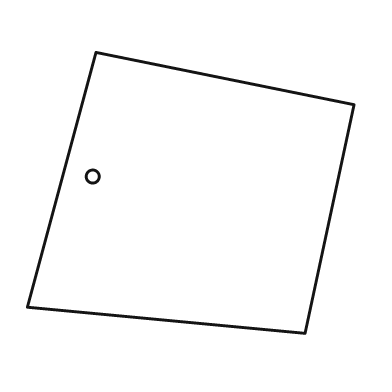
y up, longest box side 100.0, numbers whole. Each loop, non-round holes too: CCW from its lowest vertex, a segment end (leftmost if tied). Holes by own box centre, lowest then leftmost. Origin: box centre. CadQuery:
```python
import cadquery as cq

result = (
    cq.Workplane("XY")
    .moveTo(35.0, -43.0)
    .lineTo(50.0, 27.0)
    .lineTo(-29.0, 43.0)
    .lineTo(-50.0, -35.0)
    .close()
    .moveTo(-30.0, 5.0)
    .circle(2.0)
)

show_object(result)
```